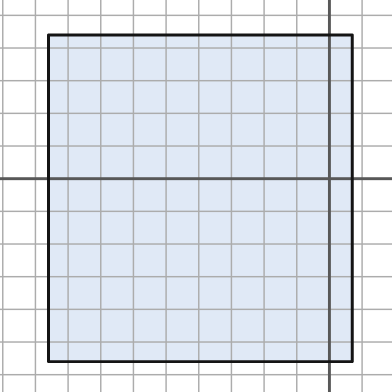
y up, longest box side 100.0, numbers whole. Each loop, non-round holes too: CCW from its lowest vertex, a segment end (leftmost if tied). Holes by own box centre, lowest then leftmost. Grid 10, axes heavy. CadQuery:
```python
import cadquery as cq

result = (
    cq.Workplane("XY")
    .moveTo(-86.0, -56.0)
    .lineTo(7.0, -56.0)
    .lineTo(7.0, 44.0)
    .lineTo(-86.0, 44.0)
    .close()
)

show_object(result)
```